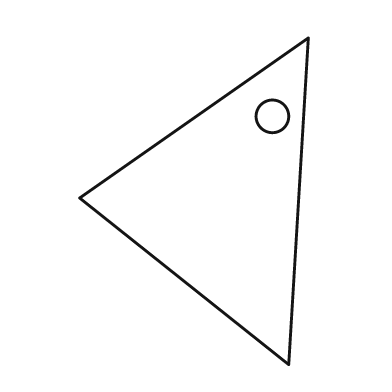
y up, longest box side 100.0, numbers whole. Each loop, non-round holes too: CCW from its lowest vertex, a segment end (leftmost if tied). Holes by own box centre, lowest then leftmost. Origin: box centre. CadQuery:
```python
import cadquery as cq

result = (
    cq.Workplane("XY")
    .moveTo(29.0, -50.0)
    .lineTo(35.0, 50.0)
    .lineTo(-35.0, 1.0)
    .close()
    .moveTo(24.0, 26.0)
    .circle(5.0)
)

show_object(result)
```